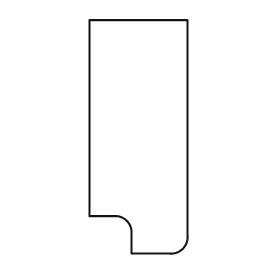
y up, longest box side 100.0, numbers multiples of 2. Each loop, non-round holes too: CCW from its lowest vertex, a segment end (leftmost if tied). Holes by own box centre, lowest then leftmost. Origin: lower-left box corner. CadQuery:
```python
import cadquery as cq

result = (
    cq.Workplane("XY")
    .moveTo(18.0, 0.0)
    .lineTo(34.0, 0.0)
    .threePointArc((40.0, 2.0), (42.0, 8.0))
    .lineTo(42.0, 100.0)
    .lineTo(0.0, 100.0)
    .lineTo(0.0, 16.0)
    .lineTo(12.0, 16.0)
    .threePointArc((16.0, 14.0), (18.0, 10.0))
    .close()
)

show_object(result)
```